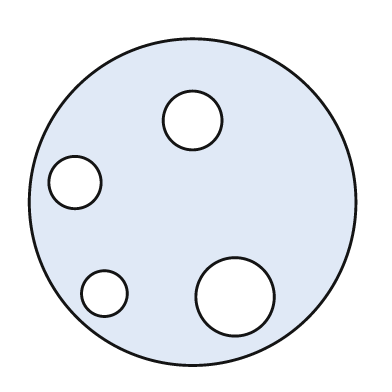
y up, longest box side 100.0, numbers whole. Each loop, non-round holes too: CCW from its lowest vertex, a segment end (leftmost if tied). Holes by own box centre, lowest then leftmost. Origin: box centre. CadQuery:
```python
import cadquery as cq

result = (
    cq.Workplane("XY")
    .moveTo(0.0, 0.0)
    .circle(50.0)
    .moveTo(13.0, -29.0)
    .circle(12.0)
    .moveTo(-27.0, -28.0)
    .circle(7.0)
    .moveTo(-36.0, 6.0)
    .circle(8.0)
    .moveTo(0.0, 25.0)
    .circle(9.0)
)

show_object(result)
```